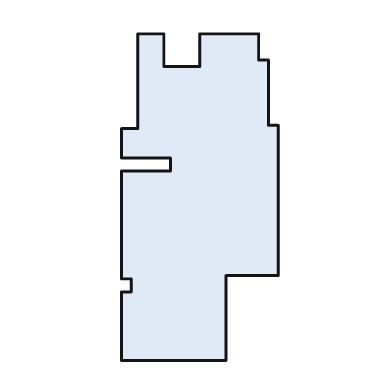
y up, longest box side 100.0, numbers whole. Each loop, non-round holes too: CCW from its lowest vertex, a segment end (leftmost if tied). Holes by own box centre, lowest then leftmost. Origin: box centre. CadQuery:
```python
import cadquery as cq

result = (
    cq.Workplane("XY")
    .moveTo(-24.0, -50.0)
    .lineTo(8.0, -50.0)
    .lineTo(8.0, -24.0)
    .lineTo(24.0, -24.0)
    .lineTo(24.0, 22.0)
    .lineTo(21.0, 22.0)
    .lineTo(21.0, 42.0)
    .lineTo(18.0, 42.0)
    .lineTo(18.0, 50.0)
    .lineTo(0.0, 50.0)
    .lineTo(0.0, 40.0)
    .lineTo(-11.0, 40.0)
    .lineTo(-11.0, 50.0)
    .lineTo(-19.0, 50.0)
    .lineTo(-19.0, 21.0)
    .lineTo(-24.0, 21.0)
    .lineTo(-24.0, 12.0)
    .lineTo(-9.0, 12.0)
    .lineTo(-9.0, 8.0)
    .lineTo(-24.0, 8.0)
    .lineTo(-24.0, -25.0)
    .lineTo(-21.0, -25.0)
    .lineTo(-21.0, -29.0)
    .lineTo(-24.0, -29.0)
    .close()
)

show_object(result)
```